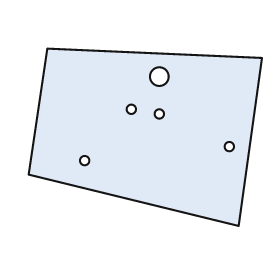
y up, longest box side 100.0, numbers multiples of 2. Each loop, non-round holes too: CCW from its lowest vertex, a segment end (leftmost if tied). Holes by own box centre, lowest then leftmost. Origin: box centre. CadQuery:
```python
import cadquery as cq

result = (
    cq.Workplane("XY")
    .moveTo(40.0, -38.0)
    .lineTo(50.0, 34.0)
    .lineTo(-42.0, 38.0)
    .lineTo(-50.0, -16.0)
    .close()
    .moveTo(-26.0, -10.0)
    .circle(2.0)
    .moveTo(36.0, -4.0)
    .circle(2.0)
    .moveTo(6.0, 10.0)
    .circle(2.0)
    .moveTo(-6.0, 12.0)
    .circle(2.0)
    .moveTo(6.0, 26.0)
    .circle(4.0)
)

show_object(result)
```